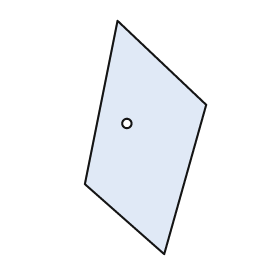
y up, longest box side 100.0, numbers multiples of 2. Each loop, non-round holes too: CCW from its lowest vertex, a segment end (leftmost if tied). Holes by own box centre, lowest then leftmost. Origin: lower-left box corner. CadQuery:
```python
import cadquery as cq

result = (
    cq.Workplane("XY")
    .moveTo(34.0, 0.0)
    .lineTo(52.0, 64.0)
    .lineTo(14.0, 100.0)
    .lineTo(0.0, 30.0)
    .close()
    .moveTo(18.0, 56.0)
    .circle(2.0)
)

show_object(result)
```